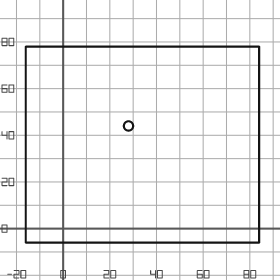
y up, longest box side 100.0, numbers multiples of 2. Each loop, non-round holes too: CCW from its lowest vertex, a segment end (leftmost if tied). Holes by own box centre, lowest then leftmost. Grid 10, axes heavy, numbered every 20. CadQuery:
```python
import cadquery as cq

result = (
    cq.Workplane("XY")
    .moveTo(-16.0, -6.0)
    .lineTo(84.0, -6.0)
    .lineTo(84.0, 78.0)
    .lineTo(-16.0, 78.0)
    .close()
    .moveTo(28.0, 44.0)
    .circle(2.0)
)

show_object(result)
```